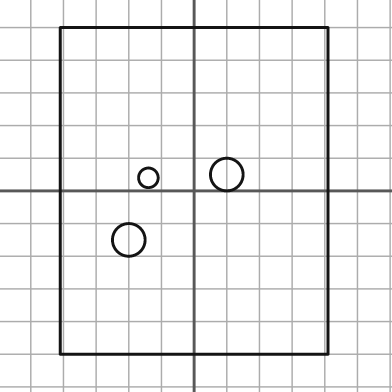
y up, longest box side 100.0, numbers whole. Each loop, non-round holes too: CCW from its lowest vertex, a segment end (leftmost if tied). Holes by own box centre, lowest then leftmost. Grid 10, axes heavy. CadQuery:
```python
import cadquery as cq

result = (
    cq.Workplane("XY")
    .moveTo(-41.0, -50.0)
    .lineTo(41.0, -50.0)
    .lineTo(41.0, 50.0)
    .lineTo(-41.0, 50.0)
    .close()
    .moveTo(-20.0, -15.0)
    .circle(5.0)
    .moveTo(-14.0, 4.0)
    .circle(3.0)
    .moveTo(10.0, 5.0)
    .circle(5.0)
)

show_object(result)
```